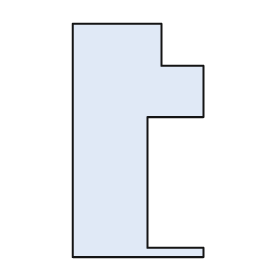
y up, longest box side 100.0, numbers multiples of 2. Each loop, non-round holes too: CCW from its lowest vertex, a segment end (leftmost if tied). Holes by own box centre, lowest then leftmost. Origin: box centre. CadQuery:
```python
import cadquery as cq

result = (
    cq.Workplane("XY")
    .moveTo(-28.0, -50.0)
    .lineTo(28.0, -50.0)
    .lineTo(28.0, -46.0)
    .lineTo(4.0, -46.0)
    .lineTo(4.0, 10.0)
    .lineTo(28.0, 10.0)
    .lineTo(28.0, 32.0)
    .lineTo(10.0, 32.0)
    .lineTo(10.0, 50.0)
    .lineTo(-28.0, 50.0)
    .close()
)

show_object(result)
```